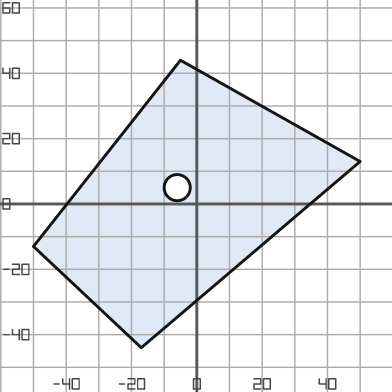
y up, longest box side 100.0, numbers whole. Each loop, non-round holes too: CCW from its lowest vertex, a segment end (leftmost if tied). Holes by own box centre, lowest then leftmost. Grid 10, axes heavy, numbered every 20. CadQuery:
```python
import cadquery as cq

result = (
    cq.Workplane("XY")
    .moveTo(-17.0, -44.0)
    .lineTo(50.0, 13.0)
    .lineTo(-5.0, 44.0)
    .lineTo(-50.0, -13.0)
    .close()
    .moveTo(-6.0, 5.0)
    .circle(4.0)
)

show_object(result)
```